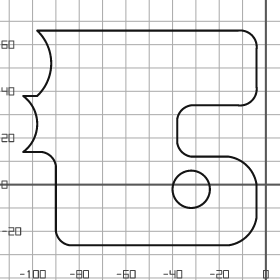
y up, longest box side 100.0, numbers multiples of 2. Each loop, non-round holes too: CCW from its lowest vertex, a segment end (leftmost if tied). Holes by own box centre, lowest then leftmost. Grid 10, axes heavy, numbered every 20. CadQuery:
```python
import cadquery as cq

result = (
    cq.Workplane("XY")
    .moveTo(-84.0, -26.0)
    .lineTo(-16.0, -26.0)
    .threePointArc((-8.0, -22.0), (-4.0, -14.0))
    .lineTo(-4.0, 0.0)
    .threePointArc((-8.0, 8.0), (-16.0, 12.0))
    .lineTo(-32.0, 12.0)
    .threePointArc((-36.0, 14.0), (-38.0, 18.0))
    .lineTo(-38.0, 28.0)
    .threePointArc((-36.0, 32.0), (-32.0, 34.0))
    .lineTo(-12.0, 34.0)
    .threePointArc((-6.0, 36.0), (-4.0, 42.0))
    .lineTo(-4.0, 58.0)
    .threePointArc((-6.0, 64.0), (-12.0, 66.0))
    .lineTo(-98.0, 66.0)
    .threePointArc((-92.0, 52.0), (-98.0, 38.0))
    .lineTo(-104.0, 38.0)
    .threePointArc((-98.0, 26.0), (-104.0, 14.0))
    .lineTo(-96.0, 14.0)
    .threePointArc((-92.0, 12.0), (-90.0, 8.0))
    .lineTo(-90.0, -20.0)
    .threePointArc((-88.0, -24.0), (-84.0, -26.0))
    .close()
    .moveTo(-32.0, -2.0)
    .circle(8.0)
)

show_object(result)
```